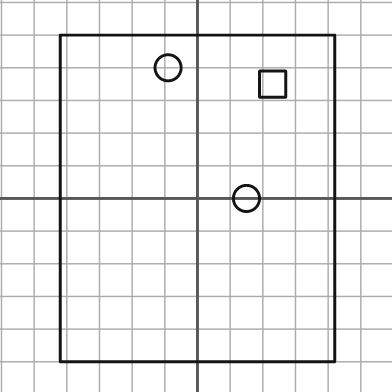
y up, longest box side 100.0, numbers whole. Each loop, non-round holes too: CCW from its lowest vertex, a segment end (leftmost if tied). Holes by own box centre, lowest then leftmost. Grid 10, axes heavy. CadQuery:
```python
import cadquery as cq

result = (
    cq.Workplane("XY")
    .moveTo(-42.0, -50.0)
    .lineTo(42.0, -50.0)
    .lineTo(42.0, 50.0)
    .lineTo(-42.0, 50.0)
    .close()
    .moveTo(15.0, 0.0)
    .circle(4.0)
    .moveTo(19.0, 31.0)
    .lineTo(27.0, 31.0)
    .lineTo(27.0, 39.0)
    .lineTo(19.0, 39.0)
    .close()
    .moveTo(-9.0, 40.0)
    .circle(4.0)
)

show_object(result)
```